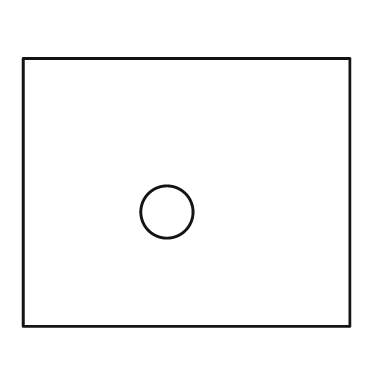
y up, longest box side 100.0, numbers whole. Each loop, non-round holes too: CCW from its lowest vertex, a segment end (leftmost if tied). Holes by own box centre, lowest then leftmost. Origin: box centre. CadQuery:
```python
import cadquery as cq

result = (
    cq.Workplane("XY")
    .moveTo(-50.0, -41.0)
    .lineTo(50.0, -41.0)
    .lineTo(50.0, 41.0)
    .lineTo(-50.0, 41.0)
    .close()
    .moveTo(-6.0, -6.0)
    .circle(8.0)
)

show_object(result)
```